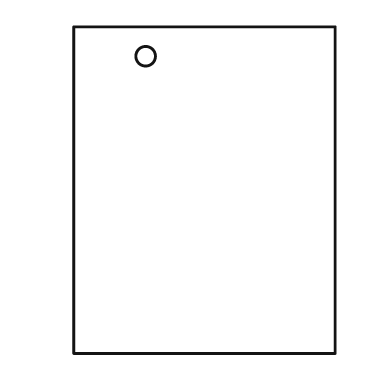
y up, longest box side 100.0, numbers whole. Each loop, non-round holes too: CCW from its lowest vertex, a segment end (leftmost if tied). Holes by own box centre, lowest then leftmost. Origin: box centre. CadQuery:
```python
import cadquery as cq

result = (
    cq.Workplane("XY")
    .moveTo(-40.0, -50.0)
    .lineTo(40.0, -50.0)
    .lineTo(40.0, 50.0)
    .lineTo(-40.0, 50.0)
    .close()
    .moveTo(-18.0, 41.0)
    .circle(3.0)
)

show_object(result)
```